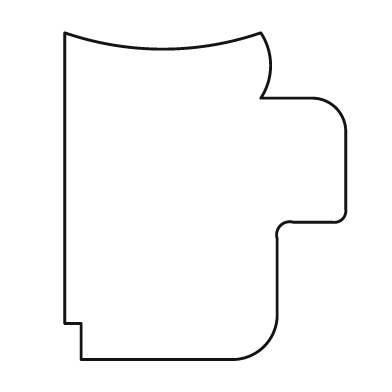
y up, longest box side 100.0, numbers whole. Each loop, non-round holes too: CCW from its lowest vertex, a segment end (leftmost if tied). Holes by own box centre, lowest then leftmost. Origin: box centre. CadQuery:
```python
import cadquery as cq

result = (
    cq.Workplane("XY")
    .moveTo(-38.0, -50.0)
    .lineTo(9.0, -50.0)
    .threePointArc((18.0, -46.0), (22.0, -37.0))
    .lineTo(22.0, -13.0)
    .threePointArc((23.0, -9.0), (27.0, -8.0))
    .lineTo(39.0, -8.0)
    .threePointArc((42.0, -7.0), (43.0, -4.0))
    .lineTo(43.0, 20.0)
    .threePointArc((40.0, 27.0), (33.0, 30.0))
    .lineTo(17.0, 30.0)
    .threePointArc((20.0, 40.0), (17.0, 50.0))
    .threePointArc((-13.0, 45.0), (-43.0, 50.0))
    .lineTo(-43.0, -39.0)
    .lineTo(-38.0, -39.0)
    .close()
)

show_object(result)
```